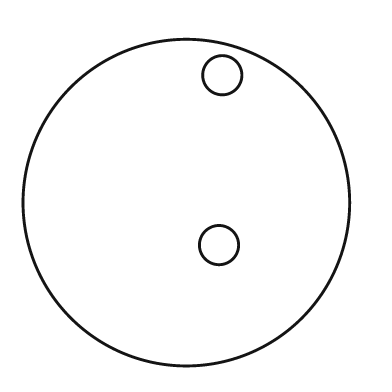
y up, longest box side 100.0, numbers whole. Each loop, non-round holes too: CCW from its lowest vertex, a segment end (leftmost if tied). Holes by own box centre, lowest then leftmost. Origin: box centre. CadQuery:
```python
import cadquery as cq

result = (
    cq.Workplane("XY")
    .moveTo(0.0, 0.0)
    .circle(50.0)
    .moveTo(10.0, -13.0)
    .circle(6.0)
    .moveTo(11.0, 39.0)
    .circle(6.0)
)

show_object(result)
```